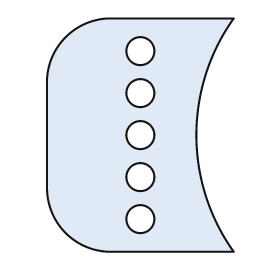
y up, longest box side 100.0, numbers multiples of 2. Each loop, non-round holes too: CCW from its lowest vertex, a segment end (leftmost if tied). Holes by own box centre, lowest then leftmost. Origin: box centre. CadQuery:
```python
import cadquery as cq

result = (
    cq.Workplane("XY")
    .moveTo(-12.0, -50.0)
    .lineTo(40.0, -50.0)
    .threePointArc((24.0, 0.0), (40.0, 50.0))
    .lineTo(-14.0, 50.0)
    .threePointArc((-32.0, 42.0), (-40.0, 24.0))
    .lineTo(-40.0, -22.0)
    .threePointArc((-32.0, -42.0), (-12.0, -50.0))
    .close()
    .moveTo(0.0, -36.0)
    .circle(6.0)
    .moveTo(0.0, -18.0)
    .circle(6.0)
    .moveTo(0.0, 0.0)
    .circle(6.0)
    .moveTo(0.0, 18.0)
    .circle(6.0)
    .moveTo(0.0, 36.0)
    .circle(6.0)
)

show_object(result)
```